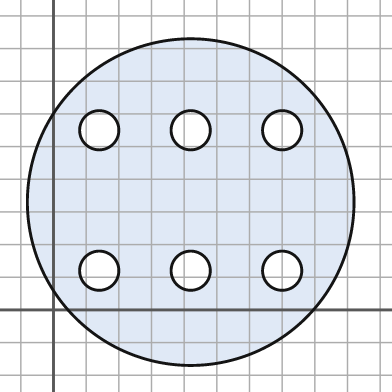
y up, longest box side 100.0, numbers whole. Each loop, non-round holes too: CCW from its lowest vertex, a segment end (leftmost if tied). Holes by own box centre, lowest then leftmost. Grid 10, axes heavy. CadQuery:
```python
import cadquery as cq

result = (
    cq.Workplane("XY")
    .moveTo(42.0, 33.0)
    .circle(50.0)
    .moveTo(14.0, 12.0)
    .circle(6.0)
    .moveTo(42.0, 12.0)
    .circle(6.0)
    .moveTo(70.0, 12.0)
    .circle(6.0)
    .moveTo(14.0, 55.0)
    .circle(6.0)
    .moveTo(42.0, 55.0)
    .circle(6.0)
    .moveTo(70.0, 55.0)
    .circle(6.0)
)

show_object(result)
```